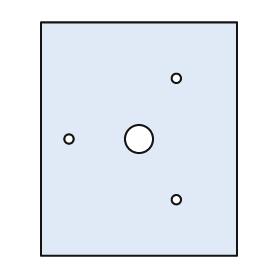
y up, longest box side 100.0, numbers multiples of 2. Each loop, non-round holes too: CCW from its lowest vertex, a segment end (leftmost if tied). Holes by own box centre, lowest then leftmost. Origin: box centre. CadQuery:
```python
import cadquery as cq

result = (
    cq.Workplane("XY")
    .moveTo(-42.0, -50.0)
    .lineTo(42.0, -50.0)
    .lineTo(42.0, 50.0)
    .lineTo(-42.0, 50.0)
    .close()
    .moveTo(16.0, -26.0)
    .circle(2.0)
    .moveTo(-30.0, 0.0)
    .circle(2.0)
    .moveTo(0.0, 0.0)
    .circle(6.0)
    .moveTo(16.0, 26.0)
    .circle(2.0)
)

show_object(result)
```